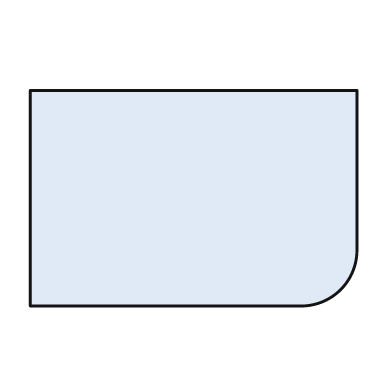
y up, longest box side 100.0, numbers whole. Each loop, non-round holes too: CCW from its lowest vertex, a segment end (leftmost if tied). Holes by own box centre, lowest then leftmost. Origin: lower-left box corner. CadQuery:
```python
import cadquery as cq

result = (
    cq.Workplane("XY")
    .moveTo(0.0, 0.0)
    .lineTo(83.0, 0.0)
    .threePointArc((95.0, 5.0), (100.0, 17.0))
    .lineTo(100.0, 66.0)
    .lineTo(0.0, 66.0)
    .close()
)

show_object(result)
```